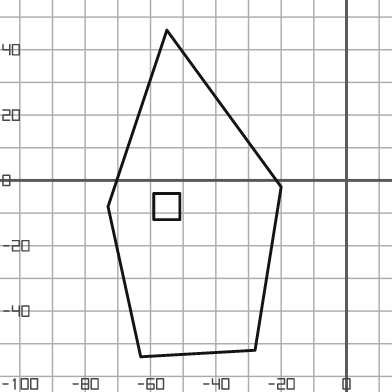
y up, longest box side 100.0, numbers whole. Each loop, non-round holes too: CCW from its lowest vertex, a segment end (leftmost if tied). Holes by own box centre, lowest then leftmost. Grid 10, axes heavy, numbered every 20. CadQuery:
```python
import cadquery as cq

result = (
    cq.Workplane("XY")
    .moveTo(-63.0, -54.0)
    .lineTo(-28.0, -52.0)
    .lineTo(-20.0, -2.0)
    .lineTo(-55.0, 46.0)
    .lineTo(-73.0, -8.0)
    .close()
    .moveTo(-59.0, -12.0)
    .lineTo(-51.0, -12.0)
    .lineTo(-51.0, -4.0)
    .lineTo(-59.0, -4.0)
    .close()
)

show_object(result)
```